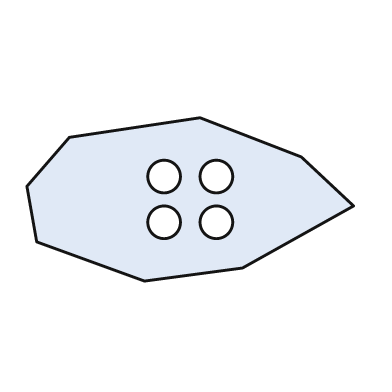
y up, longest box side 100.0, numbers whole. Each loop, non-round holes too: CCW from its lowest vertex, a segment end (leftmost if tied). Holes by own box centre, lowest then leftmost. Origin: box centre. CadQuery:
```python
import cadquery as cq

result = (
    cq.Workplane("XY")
    .moveTo(-14.0, -25.0)
    .lineTo(16.0, -21.0)
    .lineTo(50.0, -2.0)
    .lineTo(34.0, 13.0)
    .lineTo(3.0, 25.0)
    .lineTo(-37.0, 19.0)
    .lineTo(-50.0, 4.0)
    .lineTo(-47.0, -13.0)
    .close()
    .moveTo(-8.0, -7.0)
    .circle(5.0)
    .moveTo(8.0, -7.0)
    .circle(5.0)
    .moveTo(-8.0, 7.0)
    .circle(5.0)
    .moveTo(8.0, 7.0)
    .circle(5.0)
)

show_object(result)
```